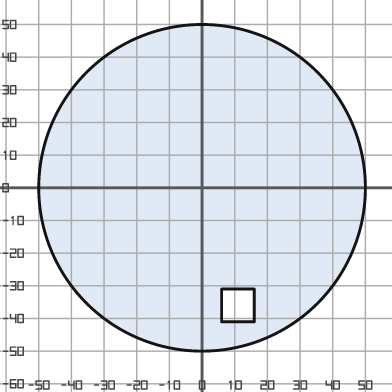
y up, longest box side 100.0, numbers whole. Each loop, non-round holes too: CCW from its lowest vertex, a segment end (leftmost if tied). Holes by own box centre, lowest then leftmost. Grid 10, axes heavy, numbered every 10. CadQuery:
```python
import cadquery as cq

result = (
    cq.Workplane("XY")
    .moveTo(0.0, 0.0)
    .circle(50.0)
    .moveTo(6.0, -41.0)
    .lineTo(16.0, -41.0)
    .lineTo(16.0, -31.0)
    .lineTo(6.0, -31.0)
    .close()
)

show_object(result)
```